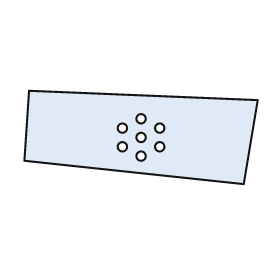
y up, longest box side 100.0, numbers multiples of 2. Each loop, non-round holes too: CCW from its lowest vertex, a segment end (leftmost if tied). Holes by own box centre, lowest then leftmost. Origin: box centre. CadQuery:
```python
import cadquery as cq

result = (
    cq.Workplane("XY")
    .moveTo(44.0, -20.0)
    .lineTo(50.0, 16.0)
    .lineTo(-48.0, 20.0)
    .lineTo(-50.0, -10.0)
    .close()
    .moveTo(0.0, -8.0)
    .circle(2.0)
    .moveTo(-8.0, -4.0)
    .circle(2.0)
    .moveTo(8.0, -4.0)
    .circle(2.0)
    .moveTo(0.0, 0.0)
    .circle(2.0)
    .moveTo(-8.0, 4.0)
    .circle(2.0)
    .moveTo(8.0, 4.0)
    .circle(2.0)
    .moveTo(0.0, 8.0)
    .circle(2.0)
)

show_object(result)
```